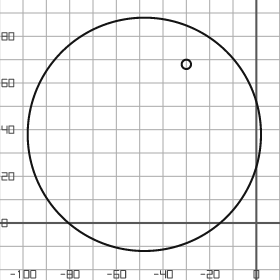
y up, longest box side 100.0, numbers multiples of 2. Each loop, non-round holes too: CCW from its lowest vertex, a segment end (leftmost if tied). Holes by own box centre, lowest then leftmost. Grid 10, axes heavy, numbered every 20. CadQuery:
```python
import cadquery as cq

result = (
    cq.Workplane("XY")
    .moveTo(-48.0, 38.0)
    .circle(50.0)
    .moveTo(-30.0, 68.0)
    .circle(2.0)
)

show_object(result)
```